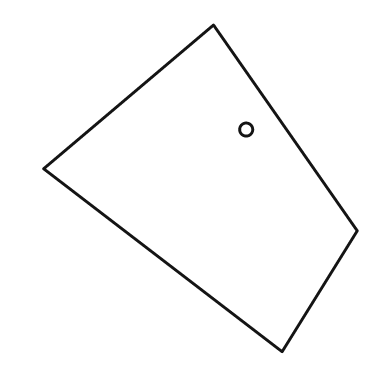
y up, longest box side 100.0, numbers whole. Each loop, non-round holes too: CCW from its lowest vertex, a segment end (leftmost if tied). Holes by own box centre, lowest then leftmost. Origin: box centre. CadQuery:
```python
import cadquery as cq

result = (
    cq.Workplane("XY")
    .moveTo(25.0, -50.0)
    .lineTo(48.0, -13.0)
    .lineTo(4.0, 50.0)
    .lineTo(-48.0, 6.0)
    .close()
    .moveTo(14.0, 18.0)
    .circle(2.0)
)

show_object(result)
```